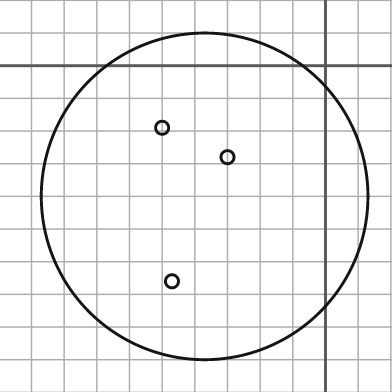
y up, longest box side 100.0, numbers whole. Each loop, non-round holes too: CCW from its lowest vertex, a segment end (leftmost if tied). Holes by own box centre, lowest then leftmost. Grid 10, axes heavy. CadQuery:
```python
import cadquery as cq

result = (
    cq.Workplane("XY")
    .moveTo(-37.0, -40.0)
    .circle(50.0)
    .moveTo(-47.0, -66.0)
    .circle(2.0)
    .moveTo(-30.0, -28.0)
    .circle(2.0)
    .moveTo(-50.0, -19.0)
    .circle(2.0)
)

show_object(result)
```